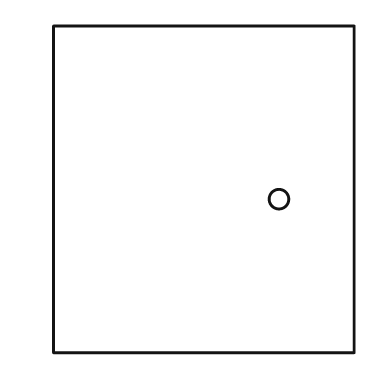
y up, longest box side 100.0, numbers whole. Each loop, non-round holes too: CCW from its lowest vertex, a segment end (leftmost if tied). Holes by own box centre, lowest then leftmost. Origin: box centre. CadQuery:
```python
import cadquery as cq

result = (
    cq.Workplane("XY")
    .moveTo(-46.0, -50.0)
    .lineTo(46.0, -50.0)
    .lineTo(46.0, 50.0)
    .lineTo(-46.0, 50.0)
    .close()
    .moveTo(23.0, -3.0)
    .circle(3.0)
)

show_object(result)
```